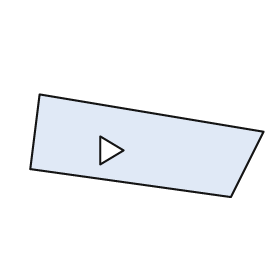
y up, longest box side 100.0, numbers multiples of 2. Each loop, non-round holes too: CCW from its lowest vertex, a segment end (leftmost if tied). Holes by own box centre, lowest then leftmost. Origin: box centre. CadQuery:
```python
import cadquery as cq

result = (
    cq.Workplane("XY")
    .moveTo(36.0, -22.0)
    .lineTo(50.0, 6.0)
    .lineTo(-46.0, 22.0)
    .lineTo(-50.0, -10.0)
    .close()
    .moveTo(-20.0, -8.0)
    .lineTo(-10.0, -2.0)
    .lineTo(-20.0, 4.0)
    .close()
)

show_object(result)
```